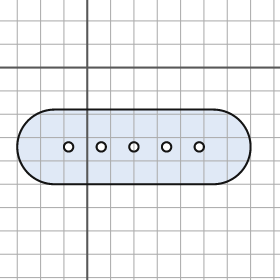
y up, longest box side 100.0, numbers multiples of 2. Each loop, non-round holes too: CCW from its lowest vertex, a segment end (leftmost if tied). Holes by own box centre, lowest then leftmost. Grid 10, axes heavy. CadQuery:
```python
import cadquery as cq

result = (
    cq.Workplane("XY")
    .moveTo(-14.0, -50.0)
    .lineTo(54.0, -50.0)
    .threePointArc((70.0, -34.0), (54.0, -18.0))
    .lineTo(-14.0, -18.0)
    .threePointArc((-30.0, -34.0), (-14.0, -50.0))
    .close()
    .moveTo(-8.0, -34.0)
    .circle(2.0)
    .moveTo(6.0, -34.0)
    .circle(2.0)
    .moveTo(20.0, -34.0)
    .circle(2.0)
    .moveTo(34.0, -34.0)
    .circle(2.0)
    .moveTo(48.0, -34.0)
    .circle(2.0)
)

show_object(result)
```